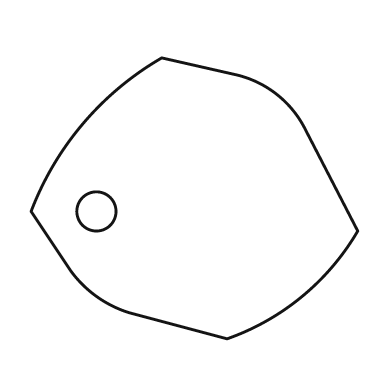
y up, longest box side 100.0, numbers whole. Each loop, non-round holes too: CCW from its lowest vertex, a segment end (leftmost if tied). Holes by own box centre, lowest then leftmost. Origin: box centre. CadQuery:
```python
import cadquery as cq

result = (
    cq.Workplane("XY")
    .moveTo(10.0, -43.0)
    .threePointArc((33.0, -30.0), (50.0, -10.0))
    .lineTo(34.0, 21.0)
    .threePointArc((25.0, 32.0), (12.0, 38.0))
    .lineTo(-10.0, 43.0)
    .threePointArc((-34.0, 23.0), (-50.0, -4.0))
    .lineTo(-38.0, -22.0)
    .threePointArc((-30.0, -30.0), (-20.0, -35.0))
    .close()
    .moveTo(-30.0, -4.0)
    .circle(6.0)
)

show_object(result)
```